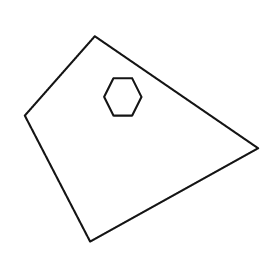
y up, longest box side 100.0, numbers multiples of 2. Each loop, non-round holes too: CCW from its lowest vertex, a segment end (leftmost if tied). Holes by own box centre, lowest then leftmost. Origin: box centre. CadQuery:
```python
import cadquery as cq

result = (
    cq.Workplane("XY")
    .moveTo(-22.0, -44.0)
    .lineTo(50.0, -4.0)
    .lineTo(-20.0, 44.0)
    .lineTo(-50.0, 10.0)
    .close()
    .moveTo(-12.0, 10.0)
    .lineTo(-4.0, 10.0)
    .lineTo(0.0, 18.0)
    .lineTo(-4.0, 26.0)
    .lineTo(-12.0, 26.0)
    .lineTo(-16.0, 18.0)
    .close()
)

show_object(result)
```